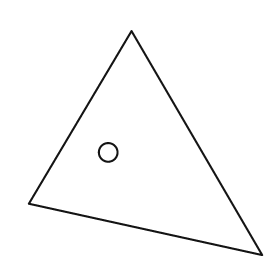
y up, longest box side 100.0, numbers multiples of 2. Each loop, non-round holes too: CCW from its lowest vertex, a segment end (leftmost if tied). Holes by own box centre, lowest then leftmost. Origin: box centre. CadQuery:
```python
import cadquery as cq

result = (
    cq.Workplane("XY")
    .moveTo(50.0, -48.0)
    .lineTo(-6.0, 48.0)
    .lineTo(-50.0, -26.0)
    .close()
    .moveTo(-16.0, -4.0)
    .circle(4.0)
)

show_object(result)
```